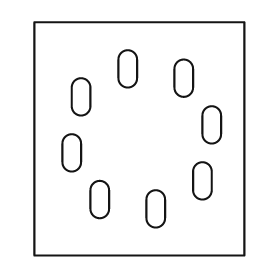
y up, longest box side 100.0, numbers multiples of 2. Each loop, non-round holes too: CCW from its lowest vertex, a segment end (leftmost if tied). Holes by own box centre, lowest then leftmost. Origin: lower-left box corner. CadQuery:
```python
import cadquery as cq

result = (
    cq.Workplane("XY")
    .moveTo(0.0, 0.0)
    .lineTo(90.0, 0.0)
    .lineTo(90.0, 100.0)
    .lineTo(0.0, 100.0)
    .close()
    .moveTo(48.0, 16.0)
    .threePointArc((52.0, 12.0), (56.0, 16.0))
    .lineTo(56.0, 24.0)
    .threePointArc((52.0, 28.0), (48.0, 24.0))
    .close()
    .moveTo(24.0, 20.0)
    .threePointArc((28.0, 16.0), (32.0, 20.0))
    .lineTo(32.0, 28.0)
    .threePointArc((28.0, 32.0), (24.0, 28.0))
    .close()
    .moveTo(68.0, 28.0)
    .threePointArc((72.0, 24.0), (76.0, 28.0))
    .lineTo(76.0, 36.0)
    .threePointArc((72.0, 40.0), (68.0, 36.0))
    .close()
    .moveTo(12.0, 40.0)
    .threePointArc((16.0, 36.0), (20.0, 40.0))
    .lineTo(20.0, 48.0)
    .threePointArc((16.0, 52.0), (12.0, 48.0))
    .close()
    .moveTo(72.0, 52.0)
    .threePointArc((76.0, 48.0), (80.0, 52.0))
    .lineTo(80.0, 60.0)
    .threePointArc((76.0, 64.0), (72.0, 60.0))
    .close()
    .moveTo(16.0, 64.0)
    .threePointArc((20.0, 60.0), (24.0, 64.0))
    .lineTo(24.0, 72.0)
    .threePointArc((20.0, 76.0), (16.0, 72.0))
    .close()
    .moveTo(60.0, 72.0)
    .threePointArc((64.0, 68.0), (68.0, 72.0))
    .lineTo(68.0, 80.0)
    .threePointArc((64.0, 84.0), (60.0, 80.0))
    .close()
    .moveTo(36.0, 76.0)
    .threePointArc((40.0, 72.0), (44.0, 76.0))
    .lineTo(44.0, 84.0)
    .threePointArc((40.0, 88.0), (36.0, 84.0))
    .close()
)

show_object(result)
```